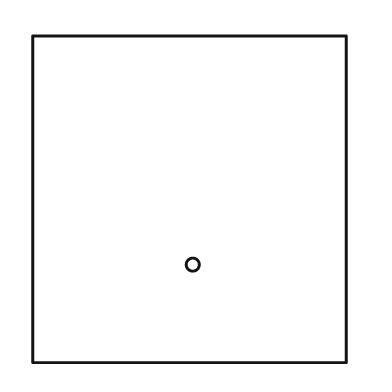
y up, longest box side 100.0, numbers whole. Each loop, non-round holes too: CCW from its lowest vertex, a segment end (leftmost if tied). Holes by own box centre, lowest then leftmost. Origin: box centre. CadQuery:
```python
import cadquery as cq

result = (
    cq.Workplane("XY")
    .moveTo(-48.0, -50.0)
    .lineTo(48.0, -50.0)
    .lineTo(48.0, 50.0)
    .lineTo(-48.0, 50.0)
    .close()
    .moveTo(1.0, -20.0)
    .circle(2.0)
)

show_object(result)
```